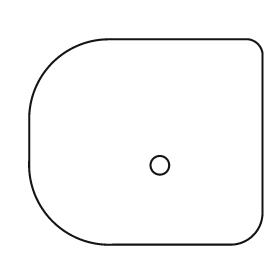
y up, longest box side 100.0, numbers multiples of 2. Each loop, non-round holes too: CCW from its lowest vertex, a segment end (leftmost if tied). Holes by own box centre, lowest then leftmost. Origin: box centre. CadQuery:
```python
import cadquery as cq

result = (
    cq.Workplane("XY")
    .moveTo(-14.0, -44.0)
    .lineTo(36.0, -44.0)
    .threePointArc((46.0, -40.0), (50.0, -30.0))
    .lineTo(50.0, 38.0)
    .threePointArc((48.0, 42.0), (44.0, 44.0))
    .lineTo(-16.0, 44.0)
    .threePointArc((-40.0, 34.0), (-50.0, 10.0))
    .lineTo(-50.0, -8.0)
    .threePointArc((-40.0, -34.0), (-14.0, -44.0))
    .close()
    .moveTo(6.0, -10.0)
    .circle(4.0)
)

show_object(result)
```